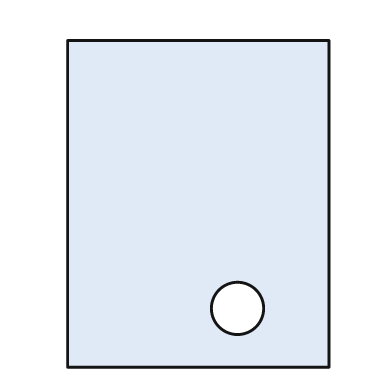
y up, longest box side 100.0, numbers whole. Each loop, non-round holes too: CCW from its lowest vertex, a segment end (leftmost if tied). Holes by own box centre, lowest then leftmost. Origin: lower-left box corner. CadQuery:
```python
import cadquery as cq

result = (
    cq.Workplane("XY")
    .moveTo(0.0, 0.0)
    .lineTo(80.0, 0.0)
    .lineTo(80.0, 100.0)
    .lineTo(0.0, 100.0)
    .close()
    .moveTo(52.0, 18.0)
    .circle(8.0)
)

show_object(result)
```